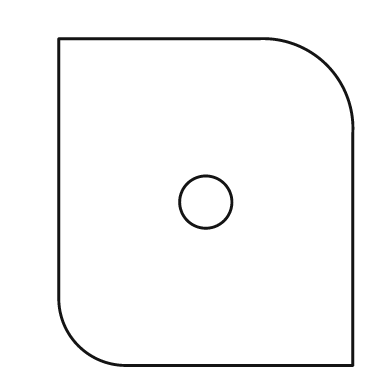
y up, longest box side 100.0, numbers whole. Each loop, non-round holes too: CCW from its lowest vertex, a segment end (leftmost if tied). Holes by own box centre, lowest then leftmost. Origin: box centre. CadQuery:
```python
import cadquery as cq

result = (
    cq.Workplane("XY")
    .moveTo(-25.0, -50.0)
    .lineTo(45.0, -50.0)
    .lineTo(45.0, 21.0)
    .threePointArc((37.0, 42.0), (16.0, 50.0))
    .lineTo(-45.0, 50.0)
    .lineTo(-45.0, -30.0)
    .threePointArc((-39.0, -44.0), (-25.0, -50.0))
    .close()
    .moveTo(0.0, 0.0)
    .circle(8.0)
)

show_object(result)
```